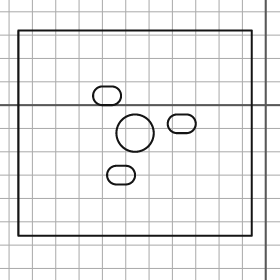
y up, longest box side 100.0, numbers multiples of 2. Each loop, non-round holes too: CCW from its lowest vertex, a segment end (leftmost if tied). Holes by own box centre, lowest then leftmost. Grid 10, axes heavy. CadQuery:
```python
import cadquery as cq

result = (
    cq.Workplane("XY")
    .moveTo(-106.0, -56.0)
    .lineTo(-6.0, -56.0)
    .lineTo(-6.0, 32.0)
    .lineTo(-106.0, 32.0)
    .close()
    .moveTo(-64.0, -34.0)
    .lineTo(-60.0, -34.0)
    .threePointArc((-56.0, -30.0), (-60.0, -26.0))
    .lineTo(-64.0, -26.0)
    .threePointArc((-68.0, -30.0), (-64.0, -34.0))
    .close()
    .moveTo(-56.0, -12.0)
    .circle(8.0)
    .moveTo(-38.0, -12.0)
    .lineTo(-34.0, -12.0)
    .threePointArc((-30.0, -8.0), (-34.0, -4.0))
    .lineTo(-38.0, -4.0)
    .threePointArc((-42.0, -8.0), (-38.0, -12.0))
    .close()
    .moveTo(-70.0, 0.0)
    .lineTo(-66.0, 0.0)
    .threePointArc((-62.0, 4.0), (-66.0, 8.0))
    .lineTo(-70.0, 8.0)
    .threePointArc((-74.0, 4.0), (-70.0, 0.0))
    .close()
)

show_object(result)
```